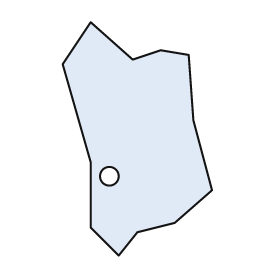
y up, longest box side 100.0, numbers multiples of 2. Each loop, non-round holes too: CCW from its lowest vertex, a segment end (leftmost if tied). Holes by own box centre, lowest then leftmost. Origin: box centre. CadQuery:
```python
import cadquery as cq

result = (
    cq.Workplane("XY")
    .moveTo(-8.0, -50.0)
    .lineTo(0.0, -40.0)
    .lineTo(16.0, -36.0)
    .lineTo(32.0, -22.0)
    .lineTo(24.0, 8.0)
    .lineTo(22.0, 36.0)
    .lineTo(10.0, 38.0)
    .lineTo(-2.0, 34.0)
    .lineTo(-20.0, 50.0)
    .lineTo(-32.0, 32.0)
    .lineTo(-20.0, -10.0)
    .lineTo(-20.0, -38.0)
    .close()
    .moveTo(-12.0, -16.0)
    .circle(4.0)
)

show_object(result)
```